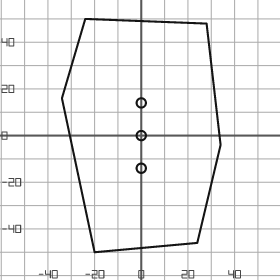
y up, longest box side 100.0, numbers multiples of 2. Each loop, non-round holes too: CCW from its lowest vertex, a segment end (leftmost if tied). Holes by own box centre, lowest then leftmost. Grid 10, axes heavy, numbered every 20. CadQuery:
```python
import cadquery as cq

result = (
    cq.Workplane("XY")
    .moveTo(-20.0, -50.0)
    .lineTo(24.0, -46.0)
    .lineTo(34.0, -4.0)
    .lineTo(28.0, 48.0)
    .lineTo(-24.0, 50.0)
    .lineTo(-34.0, 16.0)
    .close()
    .moveTo(0.0, -14.0)
    .circle(2.0)
    .moveTo(0.0, 0.0)
    .circle(2.0)
    .moveTo(0.0, 14.0)
    .circle(2.0)
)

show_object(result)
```